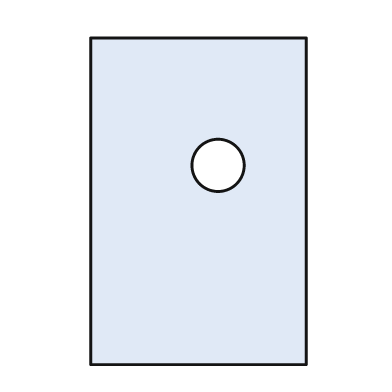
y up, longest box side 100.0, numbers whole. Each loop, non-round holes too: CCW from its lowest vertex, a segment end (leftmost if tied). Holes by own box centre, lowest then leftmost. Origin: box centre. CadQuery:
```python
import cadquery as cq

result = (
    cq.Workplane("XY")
    .moveTo(-33.0, -50.0)
    .lineTo(33.0, -50.0)
    .lineTo(33.0, 50.0)
    .lineTo(-33.0, 50.0)
    .close()
    .moveTo(6.0, 11.0)
    .circle(8.0)
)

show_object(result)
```